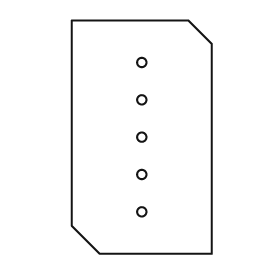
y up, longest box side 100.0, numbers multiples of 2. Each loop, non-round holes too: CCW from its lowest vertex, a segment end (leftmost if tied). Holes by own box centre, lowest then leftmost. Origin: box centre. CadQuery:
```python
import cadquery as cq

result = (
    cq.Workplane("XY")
    .moveTo(-18.0, -50.0)
    .lineTo(30.0, -50.0)
    .lineTo(30.0, 40.0)
    .lineTo(20.0, 50.0)
    .lineTo(-30.0, 50.0)
    .lineTo(-30.0, -38.0)
    .close()
    .moveTo(0.0, -32.0)
    .circle(2.0)
    .moveTo(0.0, -16.0)
    .circle(2.0)
    .moveTo(0.0, 0.0)
    .circle(2.0)
    .moveTo(0.0, 16.0)
    .circle(2.0)
    .moveTo(0.0, 32.0)
    .circle(2.0)
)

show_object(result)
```